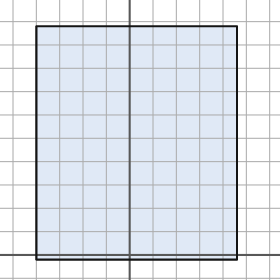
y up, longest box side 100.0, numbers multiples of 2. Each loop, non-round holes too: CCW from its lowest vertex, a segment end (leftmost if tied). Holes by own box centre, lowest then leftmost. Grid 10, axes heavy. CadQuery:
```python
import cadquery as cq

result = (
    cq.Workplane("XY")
    .moveTo(-40.0, -2.0)
    .lineTo(46.0, -2.0)
    .lineTo(46.0, 98.0)
    .lineTo(-40.0, 98.0)
    .close()
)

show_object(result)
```